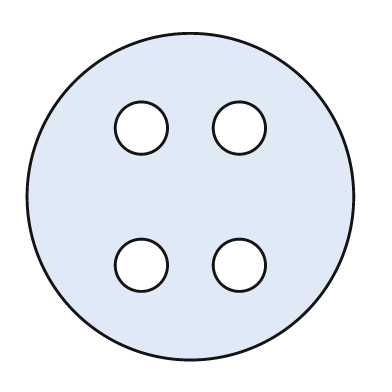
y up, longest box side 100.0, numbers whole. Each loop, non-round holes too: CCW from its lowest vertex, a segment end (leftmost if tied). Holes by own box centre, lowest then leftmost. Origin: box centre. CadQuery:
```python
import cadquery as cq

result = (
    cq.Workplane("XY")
    .moveTo(0.0, 0.0)
    .circle(50.0)
    .moveTo(-15.0, -21.0)
    .circle(8.0)
    .moveTo(15.0, -21.0)
    .circle(8.0)
    .moveTo(-15.0, 21.0)
    .circle(8.0)
    .moveTo(15.0, 21.0)
    .circle(8.0)
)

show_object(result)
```